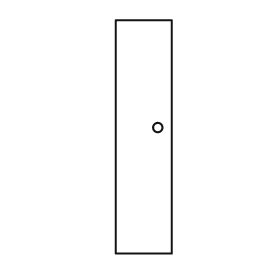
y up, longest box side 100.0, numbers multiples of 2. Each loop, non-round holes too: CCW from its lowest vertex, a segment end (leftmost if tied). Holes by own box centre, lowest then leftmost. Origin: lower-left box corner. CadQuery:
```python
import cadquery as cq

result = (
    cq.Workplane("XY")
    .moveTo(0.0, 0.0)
    .lineTo(24.0, 0.0)
    .lineTo(24.0, 100.0)
    .lineTo(0.0, 100.0)
    .close()
    .moveTo(18.0, 54.0)
    .circle(2.0)
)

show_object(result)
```